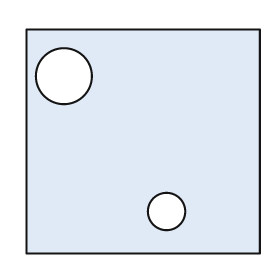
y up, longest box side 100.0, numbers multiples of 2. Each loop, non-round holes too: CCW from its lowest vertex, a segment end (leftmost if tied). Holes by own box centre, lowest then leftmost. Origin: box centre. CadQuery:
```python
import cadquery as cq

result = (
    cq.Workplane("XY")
    .moveTo(-50.0, -48.0)
    .lineTo(50.0, -48.0)
    .lineTo(50.0, 48.0)
    .lineTo(-50.0, 48.0)
    .close()
    .moveTo(10.0, -30.0)
    .circle(8.0)
    .moveTo(-34.0, 28.0)
    .circle(12.0)
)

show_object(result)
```